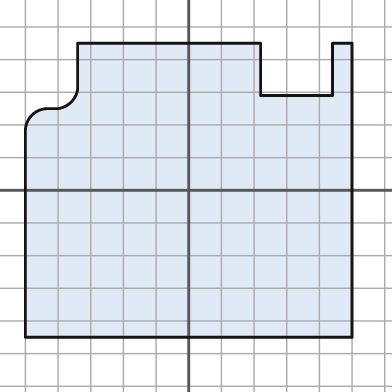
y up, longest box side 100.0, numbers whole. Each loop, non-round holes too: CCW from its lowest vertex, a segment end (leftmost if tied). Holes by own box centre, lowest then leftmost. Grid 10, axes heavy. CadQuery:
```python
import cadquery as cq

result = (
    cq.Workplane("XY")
    .moveTo(-50.0, -45.0)
    .lineTo(50.0, -45.0)
    .lineTo(50.0, 45.0)
    .lineTo(44.0, 45.0)
    .lineTo(44.0, 29.0)
    .lineTo(22.0, 29.0)
    .lineTo(22.0, 45.0)
    .lineTo(-34.0, 45.0)
    .lineTo(-34.0, 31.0)
    .threePointArc((-36.0, 27.0), (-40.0, 25.0))
    .lineTo(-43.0, 25.0)
    .threePointArc((-48.0, 23.0), (-50.0, 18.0))
    .close()
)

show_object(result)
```